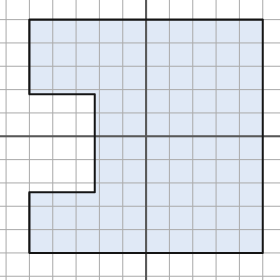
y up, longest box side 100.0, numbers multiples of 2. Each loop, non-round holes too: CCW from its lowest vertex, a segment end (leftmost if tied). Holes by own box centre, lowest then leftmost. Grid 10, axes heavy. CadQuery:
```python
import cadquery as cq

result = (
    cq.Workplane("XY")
    .moveTo(-50.0, -50.0)
    .lineTo(50.0, -50.0)
    .lineTo(50.0, 50.0)
    .lineTo(-50.0, 50.0)
    .lineTo(-50.0, 18.0)
    .lineTo(-22.0, 18.0)
    .lineTo(-22.0, -24.0)
    .lineTo(-50.0, -24.0)
    .close()
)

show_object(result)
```